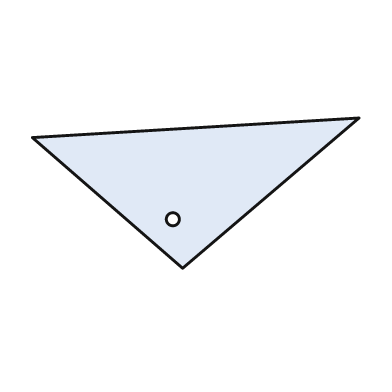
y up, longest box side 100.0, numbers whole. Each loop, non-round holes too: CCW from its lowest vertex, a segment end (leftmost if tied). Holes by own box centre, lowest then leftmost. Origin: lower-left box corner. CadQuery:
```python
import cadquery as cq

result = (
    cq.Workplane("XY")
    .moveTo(46.0, 0.0)
    .lineTo(100.0, 46.0)
    .lineTo(0.0, 40.0)
    .close()
    .moveTo(43.0, 15.0)
    .circle(2.0)
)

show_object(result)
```